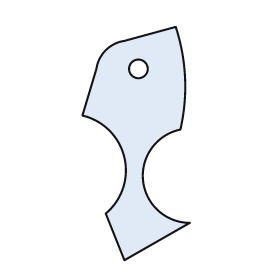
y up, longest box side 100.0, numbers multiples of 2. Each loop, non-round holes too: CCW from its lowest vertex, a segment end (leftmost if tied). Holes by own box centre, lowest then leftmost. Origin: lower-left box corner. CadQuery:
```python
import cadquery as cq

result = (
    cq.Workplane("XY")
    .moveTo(18.0, 0.0)
    .lineTo(46.0, 16.0)
    .threePointArc((26.0, 34.0), (42.0, 56.0))
    .threePointArc((44.0, 78.0), (40.0, 100.0))
    .lineTo(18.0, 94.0)
    .threePointArc((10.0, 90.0), (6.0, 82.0))
    .lineTo(0.0, 62.0)
    .threePointArc((18.0, 44.0), (10.0, 20.0))
    .close()
    .moveTo(24.0, 82.0)
    .circle(4.0)
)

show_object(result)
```